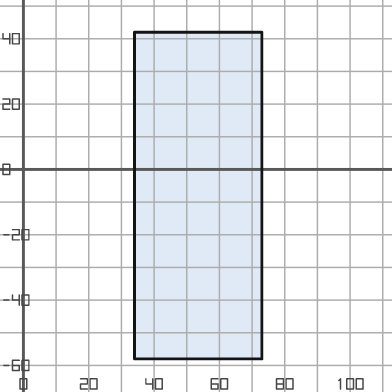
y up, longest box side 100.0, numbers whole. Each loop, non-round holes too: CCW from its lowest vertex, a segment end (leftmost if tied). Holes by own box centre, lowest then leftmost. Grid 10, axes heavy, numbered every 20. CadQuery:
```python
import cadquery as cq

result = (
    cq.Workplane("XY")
    .moveTo(34.0, -58.0)
    .lineTo(73.0, -58.0)
    .lineTo(73.0, 42.0)
    .lineTo(34.0, 42.0)
    .close()
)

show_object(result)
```